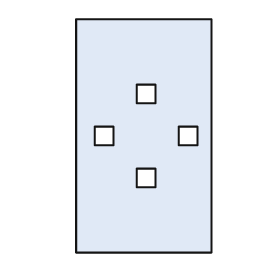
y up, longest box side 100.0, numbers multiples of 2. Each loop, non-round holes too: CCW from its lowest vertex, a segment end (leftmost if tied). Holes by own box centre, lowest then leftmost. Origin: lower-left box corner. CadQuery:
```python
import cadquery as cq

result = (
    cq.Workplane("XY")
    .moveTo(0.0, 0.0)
    .lineTo(58.0, 0.0)
    .lineTo(58.0, 100.0)
    .lineTo(0.0, 100.0)
    .close()
    .moveTo(26.0, 28.0)
    .lineTo(34.0, 28.0)
    .lineTo(34.0, 36.0)
    .lineTo(26.0, 36.0)
    .close()
    .moveTo(8.0, 46.0)
    .lineTo(16.0, 46.0)
    .lineTo(16.0, 54.0)
    .lineTo(8.0, 54.0)
    .close()
    .moveTo(44.0, 46.0)
    .lineTo(52.0, 46.0)
    .lineTo(52.0, 54.0)
    .lineTo(44.0, 54.0)
    .close()
    .moveTo(26.0, 64.0)
    .lineTo(34.0, 64.0)
    .lineTo(34.0, 72.0)
    .lineTo(26.0, 72.0)
    .close()
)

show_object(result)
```